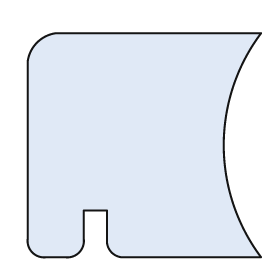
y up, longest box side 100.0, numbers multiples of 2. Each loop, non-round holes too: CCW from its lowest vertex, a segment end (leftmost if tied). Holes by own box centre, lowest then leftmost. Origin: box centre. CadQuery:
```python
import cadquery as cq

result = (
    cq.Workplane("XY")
    .moveTo(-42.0, -48.0)
    .lineTo(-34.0, -48.0)
    .threePointArc((-28.0, -46.0), (-26.0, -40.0))
    .lineTo(-26.0, -28.0)
    .lineTo(-16.0, -28.0)
    .lineTo(-16.0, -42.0)
    .threePointArc((-14.0, -46.0), (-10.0, -48.0))
    .lineTo(50.0, -48.0)
    .threePointArc((34.0, 0.0), (50.0, 48.0))
    .lineTo(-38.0, 48.0)
    .threePointArc((-46.0, 44.0), (-50.0, 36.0))
    .lineTo(-50.0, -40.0)
    .threePointArc((-48.0, -46.0), (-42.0, -48.0))
    .close()
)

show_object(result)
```